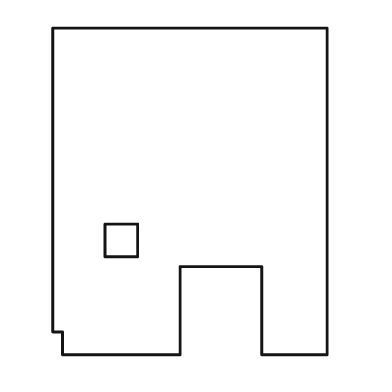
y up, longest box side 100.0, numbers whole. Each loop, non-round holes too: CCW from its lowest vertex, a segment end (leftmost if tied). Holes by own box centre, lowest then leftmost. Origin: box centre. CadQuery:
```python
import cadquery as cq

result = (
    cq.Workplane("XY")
    .moveTo(-39.0, -50.0)
    .lineTo(-3.0, -50.0)
    .lineTo(-3.0, -23.0)
    .lineTo(22.0, -23.0)
    .lineTo(22.0, -50.0)
    .lineTo(42.0, -50.0)
    .lineTo(42.0, 50.0)
    .lineTo(-42.0, 50.0)
    .lineTo(-42.0, -43.0)
    .lineTo(-39.0, -43.0)
    .close()
    .moveTo(-26.0, -20.0)
    .lineTo(-16.0, -20.0)
    .lineTo(-16.0, -10.0)
    .lineTo(-26.0, -10.0)
    .close()
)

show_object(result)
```